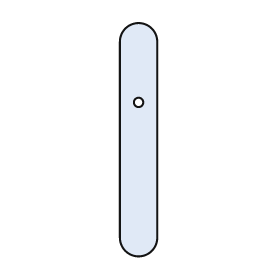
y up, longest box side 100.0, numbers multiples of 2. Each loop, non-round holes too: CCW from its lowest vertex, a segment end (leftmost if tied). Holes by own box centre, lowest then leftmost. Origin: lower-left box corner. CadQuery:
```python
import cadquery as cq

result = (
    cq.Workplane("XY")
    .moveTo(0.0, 8.0)
    .threePointArc((8.0, 0.0), (16.0, 8.0))
    .lineTo(16.0, 92.0)
    .threePointArc((8.0, 100.0), (0.0, 92.0))
    .close()
    .moveTo(8.0, 66.0)
    .circle(2.0)
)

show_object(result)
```